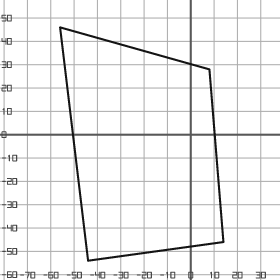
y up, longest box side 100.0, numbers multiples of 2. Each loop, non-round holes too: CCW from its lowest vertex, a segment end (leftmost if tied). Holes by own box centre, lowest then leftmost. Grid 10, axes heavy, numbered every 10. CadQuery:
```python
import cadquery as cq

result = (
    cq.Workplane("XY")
    .moveTo(-44.0, -54.0)
    .lineTo(14.0, -46.0)
    .lineTo(8.0, 28.0)
    .lineTo(-56.0, 46.0)
    .close()
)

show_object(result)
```